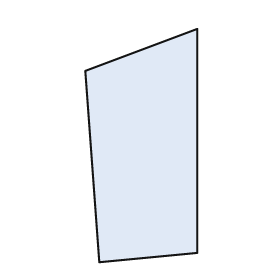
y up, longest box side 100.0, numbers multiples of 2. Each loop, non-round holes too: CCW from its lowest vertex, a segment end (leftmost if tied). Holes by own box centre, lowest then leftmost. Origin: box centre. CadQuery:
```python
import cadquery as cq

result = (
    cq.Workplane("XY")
    .moveTo(-18.0, -50.0)
    .lineTo(24.0, -46.0)
    .lineTo(24.0, 50.0)
    .lineTo(-24.0, 32.0)
    .close()
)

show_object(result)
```